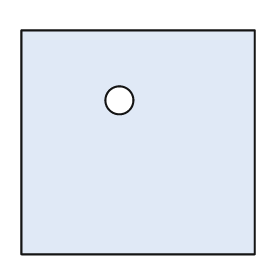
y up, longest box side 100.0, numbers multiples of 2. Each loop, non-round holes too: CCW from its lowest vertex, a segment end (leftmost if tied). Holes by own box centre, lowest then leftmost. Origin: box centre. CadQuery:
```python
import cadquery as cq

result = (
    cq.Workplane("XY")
    .moveTo(-50.0, -48.0)
    .lineTo(50.0, -48.0)
    .lineTo(50.0, 48.0)
    .lineTo(-50.0, 48.0)
    .close()
    .moveTo(-8.0, 18.0)
    .circle(6.0)
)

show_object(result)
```